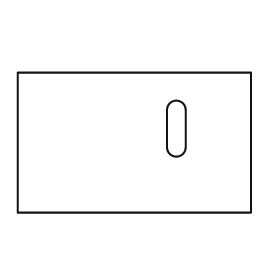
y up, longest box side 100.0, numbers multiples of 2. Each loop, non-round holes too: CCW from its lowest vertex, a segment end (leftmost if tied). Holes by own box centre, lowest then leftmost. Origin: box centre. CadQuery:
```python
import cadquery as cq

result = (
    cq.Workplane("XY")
    .moveTo(-50.0, -30.0)
    .lineTo(50.0, -30.0)
    .lineTo(50.0, 30.0)
    .lineTo(-50.0, 30.0)
    .close()
    .moveTo(14.0, -2.0)
    .threePointArc((18.0, -6.0), (22.0, -2.0))
    .lineTo(22.0, 14.0)
    .threePointArc((18.0, 18.0), (14.0, 14.0))
    .close()
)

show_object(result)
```